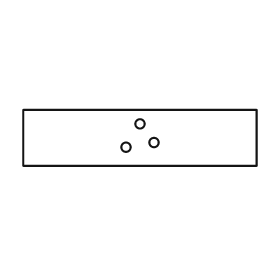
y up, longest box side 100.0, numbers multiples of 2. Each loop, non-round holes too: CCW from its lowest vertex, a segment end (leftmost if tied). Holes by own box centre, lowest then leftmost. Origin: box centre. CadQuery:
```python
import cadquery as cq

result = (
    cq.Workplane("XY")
    .moveTo(-50.0, -12.0)
    .lineTo(50.0, -12.0)
    .lineTo(50.0, 12.0)
    .lineTo(-50.0, 12.0)
    .close()
    .moveTo(-6.0, -4.0)
    .circle(2.0)
    .moveTo(6.0, -2.0)
    .circle(2.0)
    .moveTo(0.0, 6.0)
    .circle(2.0)
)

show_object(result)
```